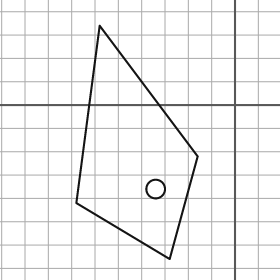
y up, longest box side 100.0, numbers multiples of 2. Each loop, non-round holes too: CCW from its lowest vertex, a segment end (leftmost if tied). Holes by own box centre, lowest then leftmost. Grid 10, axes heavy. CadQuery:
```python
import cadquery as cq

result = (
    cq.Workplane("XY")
    .moveTo(-28.0, -66.0)
    .lineTo(-16.0, -22.0)
    .lineTo(-58.0, 34.0)
    .lineTo(-68.0, -42.0)
    .close()
    .moveTo(-34.0, -36.0)
    .circle(4.0)
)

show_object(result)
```